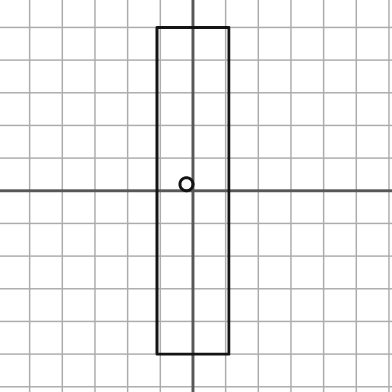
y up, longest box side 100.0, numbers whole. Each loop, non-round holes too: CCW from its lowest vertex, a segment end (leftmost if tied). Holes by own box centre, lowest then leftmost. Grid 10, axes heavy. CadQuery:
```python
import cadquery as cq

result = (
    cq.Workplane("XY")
    .moveTo(-11.0, -50.0)
    .lineTo(11.0, -50.0)
    .lineTo(11.0, 50.0)
    .lineTo(-11.0, 50.0)
    .close()
    .moveTo(-2.0, 2.0)
    .circle(2.0)
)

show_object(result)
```